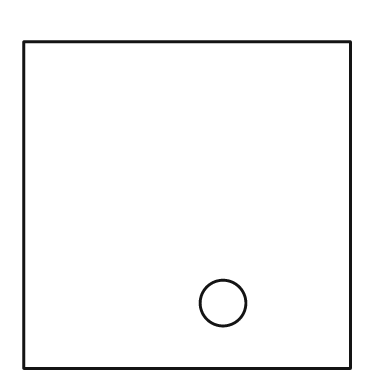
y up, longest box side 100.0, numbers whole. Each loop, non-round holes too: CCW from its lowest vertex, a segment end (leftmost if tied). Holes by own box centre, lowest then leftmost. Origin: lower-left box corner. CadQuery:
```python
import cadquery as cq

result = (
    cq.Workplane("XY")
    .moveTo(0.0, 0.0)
    .lineTo(100.0, 0.0)
    .lineTo(100.0, 100.0)
    .lineTo(0.0, 100.0)
    .close()
    .moveTo(61.0, 20.0)
    .circle(7.0)
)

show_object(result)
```